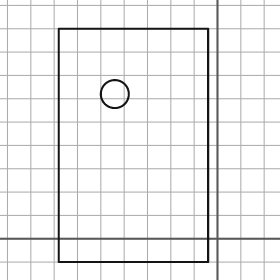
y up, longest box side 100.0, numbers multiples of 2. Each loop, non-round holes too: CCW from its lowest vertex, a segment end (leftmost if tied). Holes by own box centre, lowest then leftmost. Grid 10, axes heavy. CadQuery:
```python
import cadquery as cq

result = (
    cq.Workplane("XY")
    .moveTo(-68.0, -10.0)
    .lineTo(-4.0, -10.0)
    .lineTo(-4.0, 90.0)
    .lineTo(-68.0, 90.0)
    .close()
    .moveTo(-44.0, 62.0)
    .circle(6.0)
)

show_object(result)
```